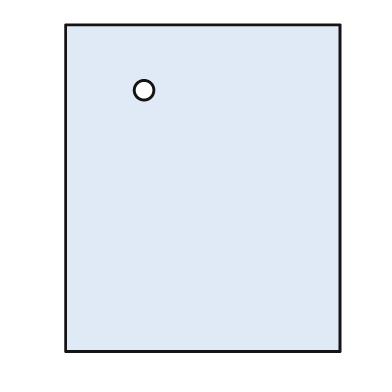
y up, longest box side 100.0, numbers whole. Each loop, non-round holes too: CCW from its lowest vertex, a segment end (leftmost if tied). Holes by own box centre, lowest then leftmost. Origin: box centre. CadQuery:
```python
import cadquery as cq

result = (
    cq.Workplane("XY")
    .moveTo(-42.0, -50.0)
    .lineTo(42.0, -50.0)
    .lineTo(42.0, 50.0)
    .lineTo(-42.0, 50.0)
    .close()
    .moveTo(-18.0, 30.0)
    .circle(3.0)
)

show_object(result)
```